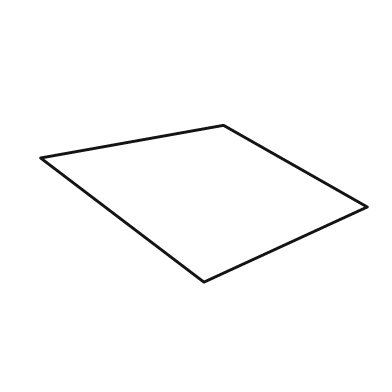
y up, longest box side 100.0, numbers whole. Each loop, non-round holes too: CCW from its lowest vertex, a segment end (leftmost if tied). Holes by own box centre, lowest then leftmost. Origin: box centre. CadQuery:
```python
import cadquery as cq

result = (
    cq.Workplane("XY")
    .moveTo(0.0, -24.0)
    .lineTo(50.0, -1.0)
    .lineTo(6.0, 24.0)
    .lineTo(-50.0, 14.0)
    .close()
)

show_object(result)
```